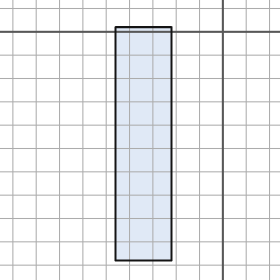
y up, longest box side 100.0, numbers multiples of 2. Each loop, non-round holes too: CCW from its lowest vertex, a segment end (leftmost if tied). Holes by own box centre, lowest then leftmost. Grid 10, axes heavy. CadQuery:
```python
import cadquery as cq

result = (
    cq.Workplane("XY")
    .moveTo(-46.0, -98.0)
    .lineTo(-22.0, -98.0)
    .lineTo(-22.0, 2.0)
    .lineTo(-46.0, 2.0)
    .close()
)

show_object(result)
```